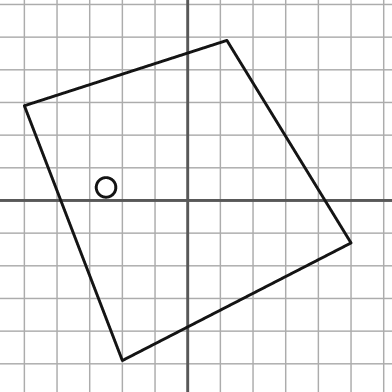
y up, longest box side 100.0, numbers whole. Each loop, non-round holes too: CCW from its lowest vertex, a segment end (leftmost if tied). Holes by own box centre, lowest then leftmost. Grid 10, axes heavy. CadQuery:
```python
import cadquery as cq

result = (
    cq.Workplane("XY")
    .moveTo(-20.0, -49.0)
    .lineTo(50.0, -13.0)
    .lineTo(12.0, 49.0)
    .lineTo(-50.0, 29.0)
    .close()
    .moveTo(-25.0, 4.0)
    .circle(3.0)
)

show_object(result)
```